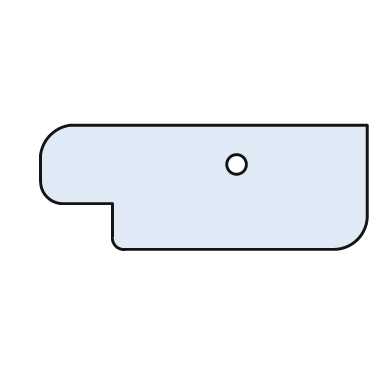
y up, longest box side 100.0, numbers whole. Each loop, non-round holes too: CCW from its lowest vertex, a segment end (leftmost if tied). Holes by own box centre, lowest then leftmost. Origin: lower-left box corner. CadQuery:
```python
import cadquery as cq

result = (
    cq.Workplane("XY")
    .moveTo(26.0, 0.0)
    .lineTo(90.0, 0.0)
    .threePointArc((97.0, 3.0), (100.0, 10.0))
    .lineTo(100.0, 38.0)
    .lineTo(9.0, 38.0)
    .threePointArc((3.0, 35.0), (0.0, 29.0))
    .lineTo(0.0, 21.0)
    .threePointArc((2.0, 16.0), (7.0, 14.0))
    .lineTo(22.0, 14.0)
    .lineTo(22.0, 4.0)
    .threePointArc((23.0, 1.0), (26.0, 0.0))
    .close()
    .moveTo(60.0, 26.0)
    .circle(3.0)
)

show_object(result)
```